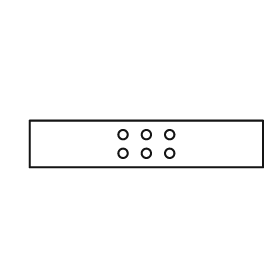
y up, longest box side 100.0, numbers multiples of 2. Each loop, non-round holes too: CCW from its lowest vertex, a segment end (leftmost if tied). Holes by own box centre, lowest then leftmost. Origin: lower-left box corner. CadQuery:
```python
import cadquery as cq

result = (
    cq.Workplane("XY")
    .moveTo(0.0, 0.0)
    .lineTo(100.0, 0.0)
    .lineTo(100.0, 20.0)
    .lineTo(0.0, 20.0)
    .close()
    .moveTo(40.0, 6.0)
    .circle(2.0)
    .moveTo(50.0, 6.0)
    .circle(2.0)
    .moveTo(60.0, 6.0)
    .circle(2.0)
    .moveTo(40.0, 14.0)
    .circle(2.0)
    .moveTo(50.0, 14.0)
    .circle(2.0)
    .moveTo(60.0, 14.0)
    .circle(2.0)
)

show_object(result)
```